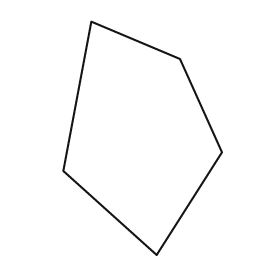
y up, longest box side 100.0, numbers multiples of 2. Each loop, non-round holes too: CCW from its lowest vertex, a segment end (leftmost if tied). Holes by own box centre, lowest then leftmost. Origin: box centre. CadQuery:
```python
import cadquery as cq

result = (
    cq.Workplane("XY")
    .moveTo(6.0, -50.0)
    .lineTo(34.0, -6.0)
    .lineTo(16.0, 34.0)
    .lineTo(-22.0, 50.0)
    .lineTo(-34.0, -14.0)
    .close()
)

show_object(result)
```